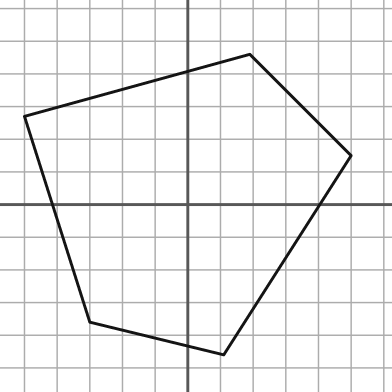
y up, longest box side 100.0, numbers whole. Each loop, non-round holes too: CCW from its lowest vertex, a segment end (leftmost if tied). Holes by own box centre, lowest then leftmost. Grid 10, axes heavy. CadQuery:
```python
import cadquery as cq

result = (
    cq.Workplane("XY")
    .moveTo(11.0, -46.0)
    .lineTo(50.0, 15.0)
    .lineTo(19.0, 46.0)
    .lineTo(-50.0, 27.0)
    .lineTo(-30.0, -36.0)
    .close()
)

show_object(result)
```